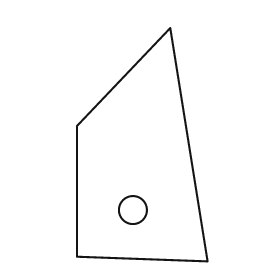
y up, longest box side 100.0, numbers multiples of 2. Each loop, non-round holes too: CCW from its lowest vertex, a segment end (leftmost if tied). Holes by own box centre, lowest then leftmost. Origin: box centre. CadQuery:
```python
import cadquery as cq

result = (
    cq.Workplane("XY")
    .moveTo(28.0, -50.0)
    .lineTo(12.0, 50.0)
    .lineTo(-28.0, 8.0)
    .lineTo(-28.0, -48.0)
    .close()
    .moveTo(-4.0, -28.0)
    .circle(6.0)
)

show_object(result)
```